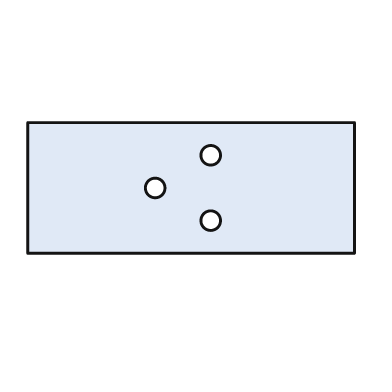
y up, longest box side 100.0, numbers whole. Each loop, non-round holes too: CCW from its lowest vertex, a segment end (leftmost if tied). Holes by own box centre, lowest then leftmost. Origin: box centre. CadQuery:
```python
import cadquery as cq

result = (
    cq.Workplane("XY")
    .moveTo(-50.0, -20.0)
    .lineTo(50.0, -20.0)
    .lineTo(50.0, 20.0)
    .lineTo(-50.0, 20.0)
    .close()
    .moveTo(6.0, -10.0)
    .circle(3.0)
    .moveTo(-11.0, 0.0)
    .circle(3.0)
    .moveTo(6.0, 10.0)
    .circle(3.0)
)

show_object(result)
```